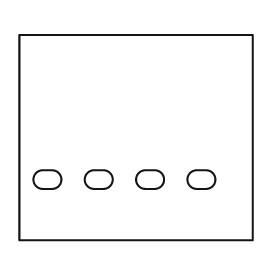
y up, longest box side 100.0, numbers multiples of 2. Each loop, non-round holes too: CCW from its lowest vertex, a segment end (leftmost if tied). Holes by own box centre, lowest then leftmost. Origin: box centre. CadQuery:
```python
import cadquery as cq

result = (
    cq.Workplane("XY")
    .moveTo(-50.0, -44.0)
    .lineTo(50.0, -44.0)
    .lineTo(50.0, 44.0)
    .lineTo(-50.0, 44.0)
    .close()
    .moveTo(-40.0, -22.0)
    .lineTo(-36.0, -22.0)
    .threePointArc((-32.0, -18.0), (-36.0, -14.0))
    .lineTo(-40.0, -14.0)
    .threePointArc((-44.0, -18.0), (-40.0, -22.0))
    .close()
    .moveTo(-18.0, -22.0)
    .lineTo(-14.0, -22.0)
    .threePointArc((-10.0, -18.0), (-14.0, -14.0))
    .lineTo(-18.0, -14.0)
    .threePointArc((-22.0, -18.0), (-18.0, -22.0))
    .close()
    .moveTo(4.0, -22.0)
    .lineTo(8.0, -22.0)
    .threePointArc((12.0, -18.0), (8.0, -14.0))
    .lineTo(4.0, -14.0)
    .threePointArc((0.0, -18.0), (4.0, -22.0))
    .close()
    .moveTo(26.0, -22.0)
    .lineTo(30.0, -22.0)
    .threePointArc((34.0, -18.0), (30.0, -14.0))
    .lineTo(26.0, -14.0)
    .threePointArc((22.0, -18.0), (26.0, -22.0))
    .close()
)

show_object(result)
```